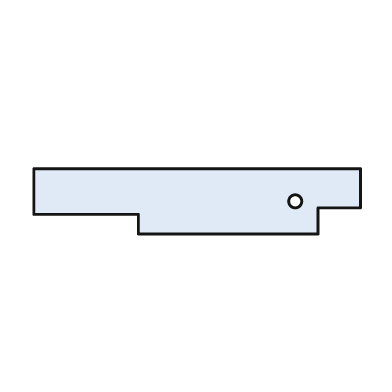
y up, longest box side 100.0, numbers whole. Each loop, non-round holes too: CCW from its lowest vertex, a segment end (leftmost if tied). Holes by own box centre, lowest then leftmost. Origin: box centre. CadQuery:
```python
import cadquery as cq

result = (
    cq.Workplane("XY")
    .moveTo(-18.0, -10.0)
    .lineTo(37.0, -10.0)
    .lineTo(37.0, -2.0)
    .lineTo(50.0, -2.0)
    .lineTo(50.0, 10.0)
    .lineTo(-50.0, 10.0)
    .lineTo(-50.0, -4.0)
    .lineTo(-18.0, -4.0)
    .close()
    .moveTo(30.0, 0.0)
    .circle(2.0)
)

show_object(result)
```